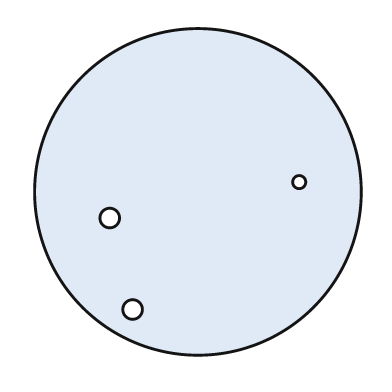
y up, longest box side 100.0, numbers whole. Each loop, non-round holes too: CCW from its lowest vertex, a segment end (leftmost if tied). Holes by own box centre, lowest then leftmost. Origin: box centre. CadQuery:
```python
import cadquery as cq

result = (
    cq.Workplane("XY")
    .moveTo(0.0, 0.0)
    .circle(50.0)
    .moveTo(-20.0, -36.0)
    .circle(3.0)
    .moveTo(-27.0, -8.0)
    .circle(3.0)
    .moveTo(31.0, 3.0)
    .circle(2.0)
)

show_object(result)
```